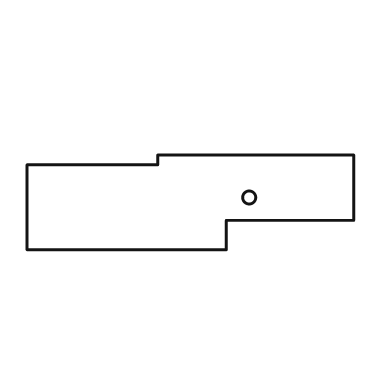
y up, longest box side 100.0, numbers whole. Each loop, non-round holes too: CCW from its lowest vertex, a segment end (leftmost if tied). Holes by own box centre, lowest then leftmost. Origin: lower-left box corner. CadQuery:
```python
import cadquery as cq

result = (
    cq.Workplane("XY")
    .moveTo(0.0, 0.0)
    .lineTo(61.0, 0.0)
    .lineTo(61.0, 9.0)
    .lineTo(100.0, 9.0)
    .lineTo(100.0, 29.0)
    .lineTo(40.0, 29.0)
    .lineTo(40.0, 26.0)
    .lineTo(0.0, 26.0)
    .close()
    .moveTo(68.0, 16.0)
    .circle(2.0)
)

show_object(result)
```